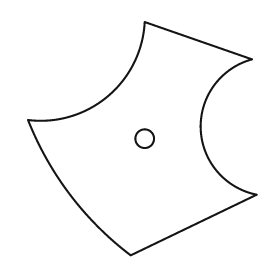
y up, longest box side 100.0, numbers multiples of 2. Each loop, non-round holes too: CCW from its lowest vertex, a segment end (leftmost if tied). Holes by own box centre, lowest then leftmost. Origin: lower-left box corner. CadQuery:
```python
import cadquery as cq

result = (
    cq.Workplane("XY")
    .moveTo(44.0, 0.0)
    .lineTo(98.0, 26.0)
    .threePointArc((74.0, 54.0), (96.0, 84.0))
    .lineTo(50.0, 100.0)
    .threePointArc((34.0, 68.0), (0.0, 58.0))
    .threePointArc((18.0, 26.0), (44.0, 0.0))
    .close()
    .moveTo(50.0, 50.0)
    .circle(4.0)
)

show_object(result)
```